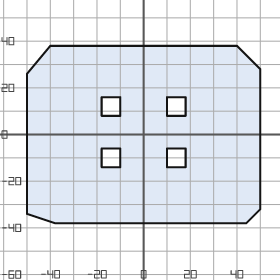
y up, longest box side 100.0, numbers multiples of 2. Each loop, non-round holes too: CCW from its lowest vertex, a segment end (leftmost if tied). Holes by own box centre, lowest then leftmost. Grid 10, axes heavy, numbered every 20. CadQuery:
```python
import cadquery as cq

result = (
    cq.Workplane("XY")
    .moveTo(-38.0, -38.0)
    .lineTo(44.0, -38.0)
    .lineTo(50.0, -32.0)
    .lineTo(50.0, 28.0)
    .lineTo(40.0, 38.0)
    .lineTo(-40.0, 38.0)
    .lineTo(-50.0, 26.0)
    .lineTo(-50.0, -34.0)
    .close()
    .moveTo(-18.0, -14.0)
    .lineTo(-10.0, -14.0)
    .lineTo(-10.0, -6.0)
    .lineTo(-18.0, -6.0)
    .close()
    .moveTo(10.0, -14.0)
    .lineTo(18.0, -14.0)
    .lineTo(18.0, -6.0)
    .lineTo(10.0, -6.0)
    .close()
    .moveTo(-18.0, 8.0)
    .lineTo(-10.0, 8.0)
    .lineTo(-10.0, 16.0)
    .lineTo(-18.0, 16.0)
    .close()
    .moveTo(10.0, 8.0)
    .lineTo(18.0, 8.0)
    .lineTo(18.0, 16.0)
    .lineTo(10.0, 16.0)
    .close()
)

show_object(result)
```